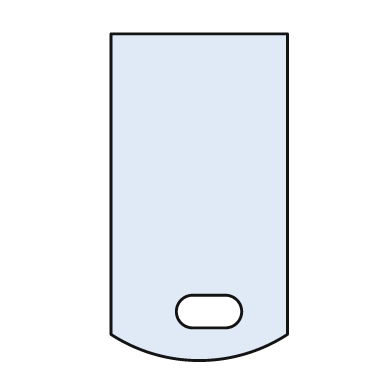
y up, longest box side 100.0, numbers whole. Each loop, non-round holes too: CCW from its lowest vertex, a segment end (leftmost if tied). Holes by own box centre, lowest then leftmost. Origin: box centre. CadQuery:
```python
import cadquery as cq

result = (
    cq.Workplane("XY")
    .moveTo(-27.0, -42.0)
    .threePointArc((0.0, -50.0), (27.0, -42.0))
    .lineTo(27.0, 50.0)
    .lineTo(-27.0, 50.0)
    .close()
    .moveTo(-2.0, -40.0)
    .lineTo(8.0, -40.0)
    .threePointArc((13.0, -35.0), (8.0, -30.0))
    .lineTo(-2.0, -30.0)
    .threePointArc((-7.0, -35.0), (-2.0, -40.0))
    .close()
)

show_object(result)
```